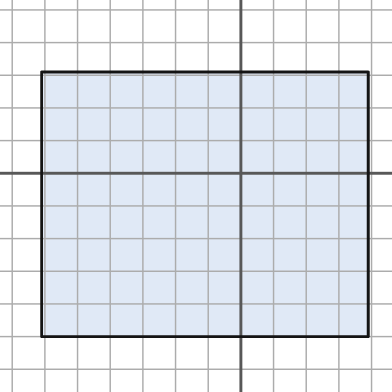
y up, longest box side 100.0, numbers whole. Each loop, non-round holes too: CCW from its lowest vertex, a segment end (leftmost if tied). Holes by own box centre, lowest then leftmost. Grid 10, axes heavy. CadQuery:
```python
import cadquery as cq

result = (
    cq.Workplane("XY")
    .moveTo(-61.0, -50.0)
    .lineTo(39.0, -50.0)
    .lineTo(39.0, 31.0)
    .lineTo(-61.0, 31.0)
    .close()
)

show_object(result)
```